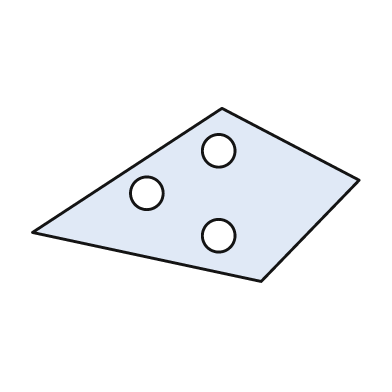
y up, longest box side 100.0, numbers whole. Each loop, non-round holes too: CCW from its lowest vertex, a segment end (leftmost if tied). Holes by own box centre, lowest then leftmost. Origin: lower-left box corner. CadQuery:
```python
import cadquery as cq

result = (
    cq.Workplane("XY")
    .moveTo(70.0, 0.0)
    .lineTo(100.0, 31.0)
    .lineTo(58.0, 53.0)
    .lineTo(0.0, 15.0)
    .close()
    .moveTo(57.0, 14.0)
    .circle(5.0)
    .moveTo(35.0, 27.0)
    .circle(5.0)
    .moveTo(57.0, 40.0)
    .circle(5.0)
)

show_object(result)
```